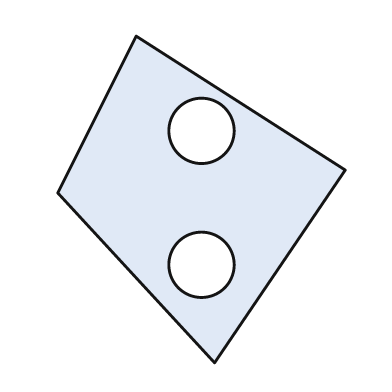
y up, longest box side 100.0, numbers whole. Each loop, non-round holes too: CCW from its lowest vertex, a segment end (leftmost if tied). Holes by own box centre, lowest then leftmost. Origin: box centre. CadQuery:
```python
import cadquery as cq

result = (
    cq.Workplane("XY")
    .moveTo(4.0, -50.0)
    .lineTo(44.0, 9.0)
    .lineTo(-20.0, 50.0)
    .lineTo(-44.0, 2.0)
    .close()
    .moveTo(0.0, -20.0)
    .circle(10.0)
    .moveTo(0.0, 21.0)
    .circle(10.0)
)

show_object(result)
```